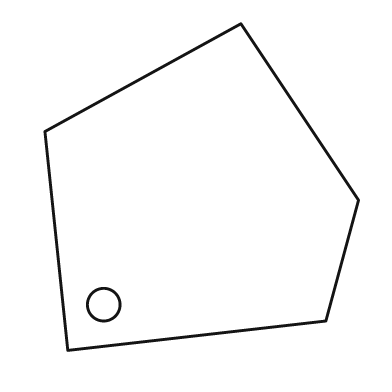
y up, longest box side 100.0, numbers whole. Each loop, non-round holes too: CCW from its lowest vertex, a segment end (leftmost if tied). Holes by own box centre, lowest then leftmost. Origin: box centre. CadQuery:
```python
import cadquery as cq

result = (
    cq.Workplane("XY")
    .moveTo(-41.0, -50.0)
    .lineTo(38.0, -41.0)
    .lineTo(48.0, -4.0)
    .lineTo(12.0, 50.0)
    .lineTo(-48.0, 17.0)
    .close()
    .moveTo(-30.0, -36.0)
    .circle(5.0)
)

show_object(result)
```